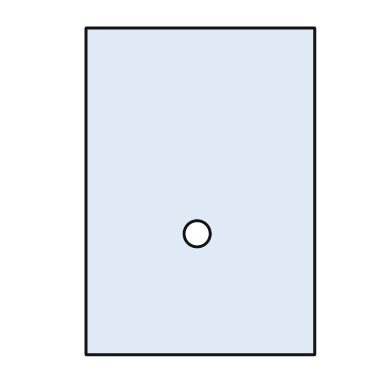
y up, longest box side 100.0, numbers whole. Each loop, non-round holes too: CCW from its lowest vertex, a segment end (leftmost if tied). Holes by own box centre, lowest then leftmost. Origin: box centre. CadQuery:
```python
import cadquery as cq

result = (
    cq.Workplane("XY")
    .moveTo(-35.0, -50.0)
    .lineTo(35.0, -50.0)
    .lineTo(35.0, 50.0)
    .lineTo(-35.0, 50.0)
    .close()
    .moveTo(-1.0, -13.0)
    .circle(4.0)
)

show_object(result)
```